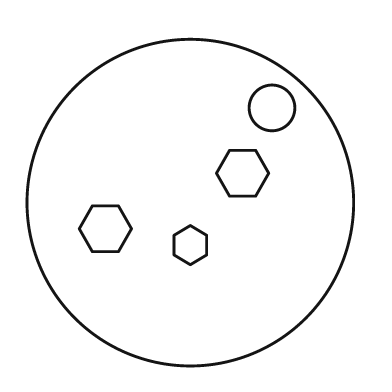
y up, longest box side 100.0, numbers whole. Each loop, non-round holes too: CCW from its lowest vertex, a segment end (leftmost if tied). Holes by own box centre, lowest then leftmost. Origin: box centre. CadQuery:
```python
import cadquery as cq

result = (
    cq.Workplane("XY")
    .moveTo(0.0, 0.0)
    .circle(50.0)
    .moveTo(0.0, -19.0)
    .lineTo(5.0, -16.0)
    .lineTo(5.0, -10.0)
    .lineTo(0.0, -7.0)
    .lineTo(-5.0, -10.0)
    .lineTo(-5.0, -16.0)
    .close()
    .moveTo(-30.0, -15.0)
    .lineTo(-22.0, -15.0)
    .lineTo(-18.0, -8.0)
    .lineTo(-22.0, -1.0)
    .lineTo(-30.0, -1.0)
    .lineTo(-34.0, -8.0)
    .close()
    .moveTo(12.0, 2.0)
    .lineTo(20.0, 2.0)
    .lineTo(24.0, 9.0)
    .lineTo(20.0, 16.0)
    .lineTo(12.0, 16.0)
    .lineTo(8.0, 9.0)
    .close()
    .moveTo(25.0, 29.0)
    .circle(7.0)
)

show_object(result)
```